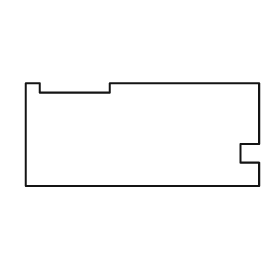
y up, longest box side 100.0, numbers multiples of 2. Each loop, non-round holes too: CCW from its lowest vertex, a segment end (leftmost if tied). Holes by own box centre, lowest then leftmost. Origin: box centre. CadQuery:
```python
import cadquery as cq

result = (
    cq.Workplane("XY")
    .moveTo(-50.0, -22.0)
    .lineTo(50.0, -22.0)
    .lineTo(50.0, -12.0)
    .lineTo(42.0, -12.0)
    .lineTo(42.0, -4.0)
    .lineTo(50.0, -4.0)
    .lineTo(50.0, 22.0)
    .lineTo(-14.0, 22.0)
    .lineTo(-14.0, 18.0)
    .lineTo(-44.0, 18.0)
    .lineTo(-44.0, 22.0)
    .lineTo(-50.0, 22.0)
    .close()
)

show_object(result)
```